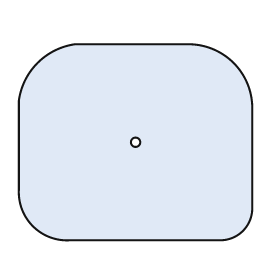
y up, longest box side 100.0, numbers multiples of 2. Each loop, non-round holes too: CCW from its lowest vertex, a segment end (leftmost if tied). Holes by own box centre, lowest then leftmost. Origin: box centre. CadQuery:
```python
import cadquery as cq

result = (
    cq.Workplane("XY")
    .moveTo(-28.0, -42.0)
    .lineTo(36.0, -42.0)
    .threePointArc((46.0, -38.0), (50.0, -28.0))
    .lineTo(50.0, 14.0)
    .threePointArc((42.0, 34.0), (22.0, 42.0))
    .lineTo(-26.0, 42.0)
    .threePointArc((-42.0, 34.0), (-50.0, 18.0))
    .lineTo(-50.0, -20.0)
    .threePointArc((-44.0, -36.0), (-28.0, -42.0))
    .close()
    .moveTo(0.0, 0.0)
    .circle(2.0)
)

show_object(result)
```